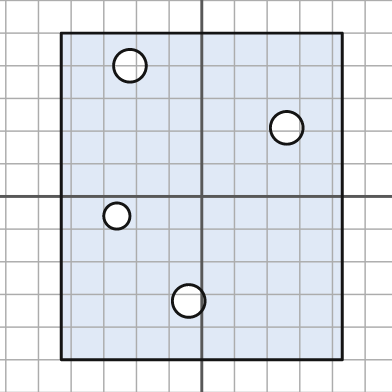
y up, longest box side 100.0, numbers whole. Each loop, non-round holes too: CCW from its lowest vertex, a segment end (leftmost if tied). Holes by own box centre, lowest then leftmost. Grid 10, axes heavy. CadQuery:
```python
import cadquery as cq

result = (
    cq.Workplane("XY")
    .moveTo(-43.0, -50.0)
    .lineTo(43.0, -50.0)
    .lineTo(43.0, 50.0)
    .lineTo(-43.0, 50.0)
    .close()
    .moveTo(-4.0, -32.0)
    .circle(5.0)
    .moveTo(-26.0, -6.0)
    .circle(4.0)
    .moveTo(26.0, 21.0)
    .circle(5.0)
    .moveTo(-22.0, 40.0)
    .circle(5.0)
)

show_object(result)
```